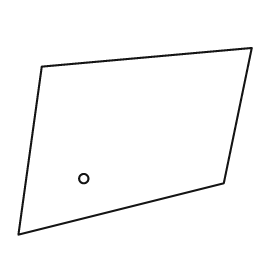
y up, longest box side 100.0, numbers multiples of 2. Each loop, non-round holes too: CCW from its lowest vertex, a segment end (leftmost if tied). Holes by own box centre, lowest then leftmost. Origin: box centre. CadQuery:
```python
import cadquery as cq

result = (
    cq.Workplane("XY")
    .moveTo(-50.0, -40.0)
    .lineTo(38.0, -18.0)
    .lineTo(50.0, 40.0)
    .lineTo(-40.0, 32.0)
    .close()
    .moveTo(-22.0, -16.0)
    .circle(2.0)
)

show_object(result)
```